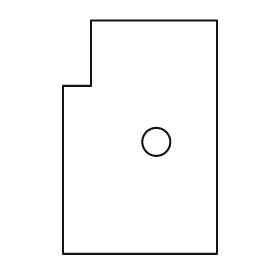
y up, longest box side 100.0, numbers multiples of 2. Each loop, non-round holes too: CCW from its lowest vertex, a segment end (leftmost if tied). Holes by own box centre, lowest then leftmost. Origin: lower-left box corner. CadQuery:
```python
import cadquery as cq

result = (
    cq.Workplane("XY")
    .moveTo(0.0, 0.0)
    .lineTo(66.0, 0.0)
    .lineTo(66.0, 100.0)
    .lineTo(12.0, 100.0)
    .lineTo(12.0, 72.0)
    .lineTo(0.0, 72.0)
    .close()
    .moveTo(40.0, 48.0)
    .circle(6.0)
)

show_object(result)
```